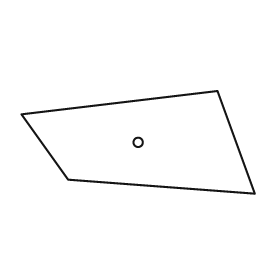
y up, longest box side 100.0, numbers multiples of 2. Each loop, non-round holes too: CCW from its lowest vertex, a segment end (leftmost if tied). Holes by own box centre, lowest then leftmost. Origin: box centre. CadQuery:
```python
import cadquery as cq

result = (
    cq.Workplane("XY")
    .moveTo(50.0, -22.0)
    .lineTo(34.0, 22.0)
    .lineTo(-50.0, 12.0)
    .lineTo(-30.0, -16.0)
    .close()
    .moveTo(0.0, 0.0)
    .circle(2.0)
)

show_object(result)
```